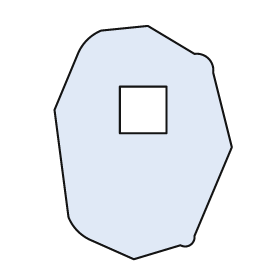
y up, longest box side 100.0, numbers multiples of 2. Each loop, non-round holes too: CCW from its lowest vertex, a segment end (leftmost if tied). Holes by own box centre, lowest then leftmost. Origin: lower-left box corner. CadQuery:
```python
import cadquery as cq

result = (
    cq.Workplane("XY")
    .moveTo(34.0, 0.0)
    .lineTo(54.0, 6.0)
    .threePointArc((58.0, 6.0), (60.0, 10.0))
    .lineTo(76.0, 48.0)
    .lineTo(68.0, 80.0)
    .threePointArc((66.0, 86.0), (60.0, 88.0))
    .lineTo(40.0, 100.0)
    .lineTo(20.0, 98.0)
    .threePointArc((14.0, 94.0), (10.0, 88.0))
    .lineTo(0.0, 64.0)
    .lineTo(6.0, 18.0)
    .threePointArc((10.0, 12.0), (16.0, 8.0))
    .close()
    .moveTo(28.0, 54.0)
    .lineTo(48.0, 54.0)
    .lineTo(48.0, 74.0)
    .lineTo(28.0, 74.0)
    .close()
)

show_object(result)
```